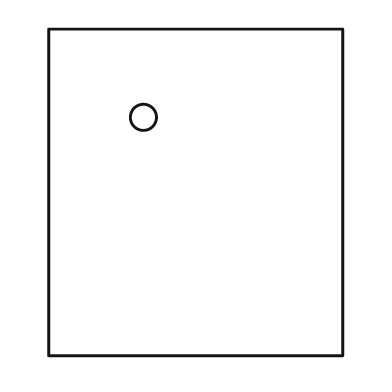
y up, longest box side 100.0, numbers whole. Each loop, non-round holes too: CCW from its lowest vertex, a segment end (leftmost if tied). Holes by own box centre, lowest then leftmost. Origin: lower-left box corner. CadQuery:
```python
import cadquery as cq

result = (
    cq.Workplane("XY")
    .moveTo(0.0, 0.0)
    .lineTo(90.0, 0.0)
    .lineTo(90.0, 100.0)
    .lineTo(0.0, 100.0)
    .close()
    .moveTo(29.0, 73.0)
    .circle(4.0)
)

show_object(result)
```